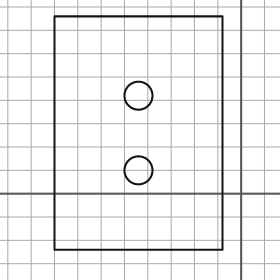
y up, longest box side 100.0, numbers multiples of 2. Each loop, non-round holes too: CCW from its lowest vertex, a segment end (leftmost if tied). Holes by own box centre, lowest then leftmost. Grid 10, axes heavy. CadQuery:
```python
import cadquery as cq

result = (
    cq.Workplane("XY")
    .moveTo(-80.0, -24.0)
    .lineTo(-8.0, -24.0)
    .lineTo(-8.0, 76.0)
    .lineTo(-80.0, 76.0)
    .close()
    .moveTo(-44.0, 10.0)
    .circle(6.0)
    .moveTo(-44.0, 42.0)
    .circle(6.0)
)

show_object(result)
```